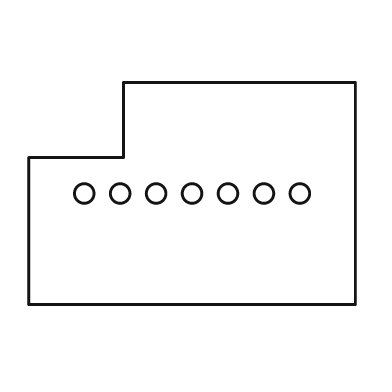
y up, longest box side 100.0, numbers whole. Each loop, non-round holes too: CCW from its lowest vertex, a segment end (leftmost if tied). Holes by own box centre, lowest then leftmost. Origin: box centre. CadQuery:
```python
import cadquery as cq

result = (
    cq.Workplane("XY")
    .moveTo(-50.0, -34.0)
    .lineTo(50.0, -34.0)
    .lineTo(50.0, 34.0)
    .lineTo(-21.0, 34.0)
    .lineTo(-21.0, 11.0)
    .lineTo(-50.0, 11.0)
    .close()
    .moveTo(-33.0, 0.0)
    .circle(3.0)
    .moveTo(-22.0, 0.0)
    .circle(3.0)
    .moveTo(-11.0, 0.0)
    .circle(3.0)
    .moveTo(0.0, 0.0)
    .circle(3.0)
    .moveTo(11.0, 0.0)
    .circle(3.0)
    .moveTo(22.0, 0.0)
    .circle(3.0)
    .moveTo(33.0, 0.0)
    .circle(3.0)
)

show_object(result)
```